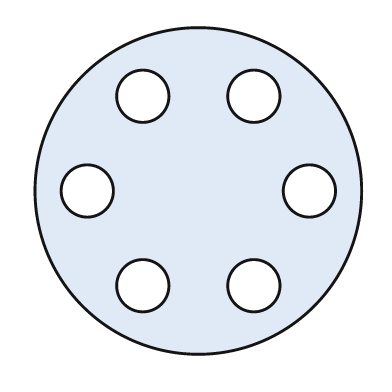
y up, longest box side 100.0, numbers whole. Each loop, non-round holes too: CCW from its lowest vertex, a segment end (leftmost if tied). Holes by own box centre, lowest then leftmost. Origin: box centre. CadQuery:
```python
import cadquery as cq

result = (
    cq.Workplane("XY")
    .moveTo(0.0, 0.0)
    .circle(50.0)
    .moveTo(-17.0, -29.0)
    .circle(8.0)
    .moveTo(17.0, -29.0)
    .circle(8.0)
    .moveTo(-34.0, 0.0)
    .circle(8.0)
    .moveTo(34.0, 0.0)
    .circle(8.0)
    .moveTo(-17.0, 29.0)
    .circle(8.0)
    .moveTo(17.0, 29.0)
    .circle(8.0)
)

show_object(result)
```